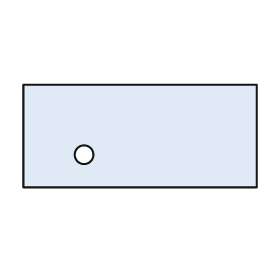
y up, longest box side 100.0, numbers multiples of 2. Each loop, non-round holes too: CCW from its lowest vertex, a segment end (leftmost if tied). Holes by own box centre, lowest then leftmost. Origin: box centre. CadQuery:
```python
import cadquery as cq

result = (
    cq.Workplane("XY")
    .moveTo(-50.0, -22.0)
    .lineTo(50.0, -22.0)
    .lineTo(50.0, 22.0)
    .lineTo(-50.0, 22.0)
    .close()
    .moveTo(-24.0, -8.0)
    .circle(4.0)
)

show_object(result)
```